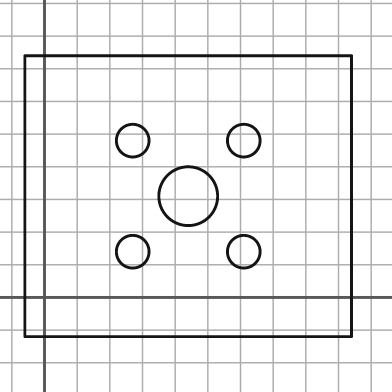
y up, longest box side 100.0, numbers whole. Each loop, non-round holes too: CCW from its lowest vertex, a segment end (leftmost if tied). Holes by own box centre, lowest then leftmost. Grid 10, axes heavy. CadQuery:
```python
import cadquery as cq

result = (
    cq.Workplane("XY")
    .moveTo(-6.0, -12.0)
    .lineTo(94.0, -12.0)
    .lineTo(94.0, 74.0)
    .lineTo(-6.0, 74.0)
    .close()
    .moveTo(27.0, 14.0)
    .circle(5.0)
    .moveTo(61.0, 14.0)
    .circle(5.0)
    .moveTo(44.0, 31.0)
    .circle(9.0)
    .moveTo(27.0, 48.0)
    .circle(5.0)
    .moveTo(61.0, 48.0)
    .circle(5.0)
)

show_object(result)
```